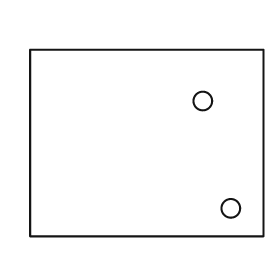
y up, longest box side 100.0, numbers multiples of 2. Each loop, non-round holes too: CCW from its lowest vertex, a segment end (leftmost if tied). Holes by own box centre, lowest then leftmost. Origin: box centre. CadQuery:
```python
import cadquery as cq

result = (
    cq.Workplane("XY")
    .moveTo(-50.0, -40.0)
    .lineTo(50.0, -40.0)
    .lineTo(50.0, 40.0)
    .lineTo(-50.0, 40.0)
    .close()
    .moveTo(36.0, -28.0)
    .circle(4.0)
    .moveTo(24.0, 18.0)
    .circle(4.0)
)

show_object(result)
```